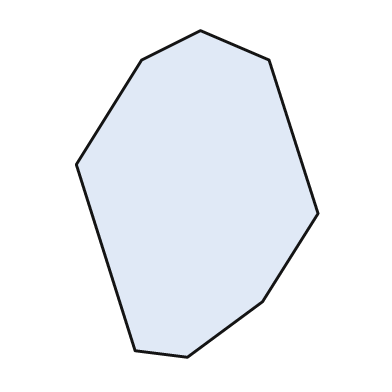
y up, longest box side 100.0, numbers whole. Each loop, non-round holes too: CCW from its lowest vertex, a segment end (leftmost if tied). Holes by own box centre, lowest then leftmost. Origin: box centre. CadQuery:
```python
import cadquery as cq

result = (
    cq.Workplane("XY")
    .moveTo(-3.0, -50.0)
    .lineTo(20.0, -33.0)
    .lineTo(37.0, -6.0)
    .lineTo(22.0, 41.0)
    .lineTo(1.0, 50.0)
    .lineTo(-17.0, 41.0)
    .lineTo(-37.0, 9.0)
    .lineTo(-19.0, -48.0)
    .close()
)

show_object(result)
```